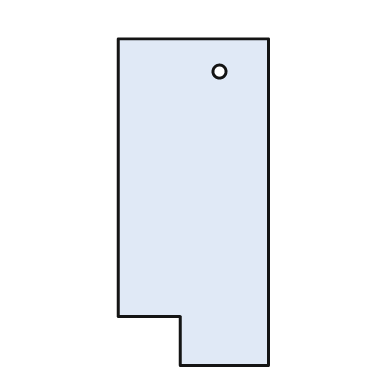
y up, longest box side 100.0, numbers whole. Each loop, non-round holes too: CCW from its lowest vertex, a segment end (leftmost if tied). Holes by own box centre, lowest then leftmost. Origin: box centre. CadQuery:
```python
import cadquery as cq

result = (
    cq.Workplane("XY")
    .moveTo(-4.0, -50.0)
    .lineTo(23.0, -50.0)
    .lineTo(23.0, 50.0)
    .lineTo(-23.0, 50.0)
    .lineTo(-23.0, -35.0)
    .lineTo(-4.0, -35.0)
    .close()
    .moveTo(8.0, 40.0)
    .circle(2.0)
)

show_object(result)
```